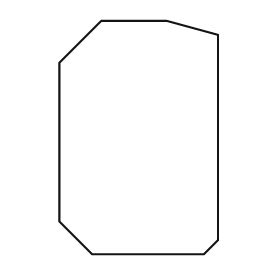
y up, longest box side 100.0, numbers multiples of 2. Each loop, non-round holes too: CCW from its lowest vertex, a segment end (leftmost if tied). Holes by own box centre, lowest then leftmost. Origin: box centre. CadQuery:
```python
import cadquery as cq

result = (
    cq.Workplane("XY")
    .moveTo(-20.0, -50.0)
    .lineTo(28.0, -50.0)
    .lineTo(34.0, -44.0)
    .lineTo(34.0, 44.0)
    .lineTo(12.0, 50.0)
    .lineTo(-16.0, 50.0)
    .lineTo(-34.0, 32.0)
    .lineTo(-34.0, -36.0)
    .close()
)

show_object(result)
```